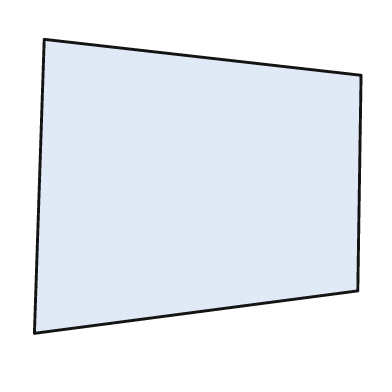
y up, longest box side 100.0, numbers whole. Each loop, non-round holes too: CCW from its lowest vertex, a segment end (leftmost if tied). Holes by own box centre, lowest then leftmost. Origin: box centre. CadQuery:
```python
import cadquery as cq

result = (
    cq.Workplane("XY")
    .moveTo(-50.0, -45.0)
    .lineTo(49.0, -32.0)
    .lineTo(50.0, 34.0)
    .lineTo(-47.0, 45.0)
    .close()
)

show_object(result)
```